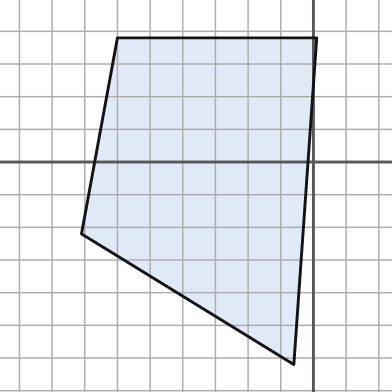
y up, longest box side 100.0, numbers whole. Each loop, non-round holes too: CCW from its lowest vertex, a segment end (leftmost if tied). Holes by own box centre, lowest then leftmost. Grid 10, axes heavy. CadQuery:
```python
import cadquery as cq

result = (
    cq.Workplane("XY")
    .moveTo(-6.0, -62.0)
    .lineTo(1.0, 38.0)
    .lineTo(-60.0, 38.0)
    .lineTo(-71.0, -22.0)
    .close()
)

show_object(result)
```